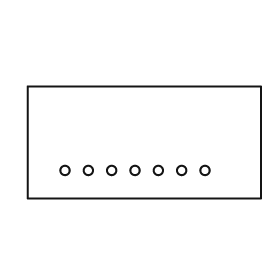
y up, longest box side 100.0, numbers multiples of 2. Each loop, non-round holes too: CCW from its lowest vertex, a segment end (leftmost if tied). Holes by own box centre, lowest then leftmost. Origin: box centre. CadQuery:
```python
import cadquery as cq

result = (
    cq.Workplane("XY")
    .moveTo(-50.0, -24.0)
    .lineTo(50.0, -24.0)
    .lineTo(50.0, 24.0)
    .lineTo(-50.0, 24.0)
    .close()
    .moveTo(-34.0, -12.0)
    .circle(2.0)
    .moveTo(-24.0, -12.0)
    .circle(2.0)
    .moveTo(-14.0, -12.0)
    .circle(2.0)
    .moveTo(-4.0, -12.0)
    .circle(2.0)
    .moveTo(6.0, -12.0)
    .circle(2.0)
    .moveTo(16.0, -12.0)
    .circle(2.0)
    .moveTo(26.0, -12.0)
    .circle(2.0)
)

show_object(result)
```